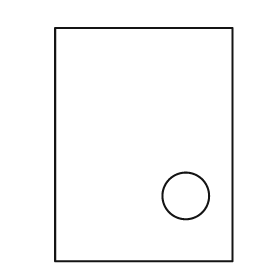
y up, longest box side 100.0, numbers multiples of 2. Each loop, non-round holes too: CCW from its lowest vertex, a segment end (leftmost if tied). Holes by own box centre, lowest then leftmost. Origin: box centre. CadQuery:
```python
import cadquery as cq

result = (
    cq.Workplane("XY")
    .moveTo(-38.0, -50.0)
    .lineTo(38.0, -50.0)
    .lineTo(38.0, 50.0)
    .lineTo(-38.0, 50.0)
    .close()
    .moveTo(18.0, -22.0)
    .circle(10.0)
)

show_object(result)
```